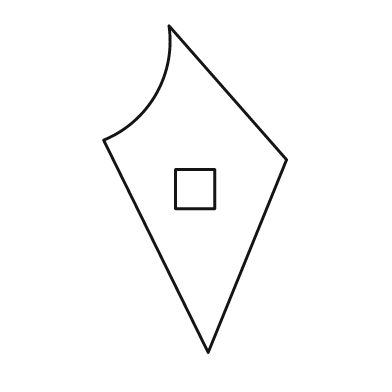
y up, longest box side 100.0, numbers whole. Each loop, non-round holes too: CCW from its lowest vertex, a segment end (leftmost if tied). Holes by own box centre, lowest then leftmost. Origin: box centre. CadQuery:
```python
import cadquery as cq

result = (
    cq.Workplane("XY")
    .moveTo(4.0, -50.0)
    .lineTo(28.0, 9.0)
    .lineTo(-8.0, 50.0)
    .threePointArc((-12.0, 29.0), (-28.0, 15.0))
    .close()
    .moveTo(-6.0, -6.0)
    .lineTo(6.0, -6.0)
    .lineTo(6.0, 6.0)
    .lineTo(-6.0, 6.0)
    .close()
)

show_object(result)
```